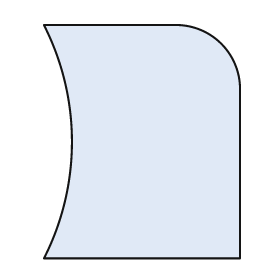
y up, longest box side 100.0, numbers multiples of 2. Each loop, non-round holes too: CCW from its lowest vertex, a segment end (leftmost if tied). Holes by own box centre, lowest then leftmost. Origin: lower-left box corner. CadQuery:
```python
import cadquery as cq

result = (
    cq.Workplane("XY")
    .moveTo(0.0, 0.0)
    .lineTo(84.0, 0.0)
    .lineTo(84.0, 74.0)
    .threePointArc((76.0, 92.0), (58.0, 100.0))
    .lineTo(0.0, 100.0)
    .threePointArc((12.0, 50.0), (0.0, 0.0))
    .close()
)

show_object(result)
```